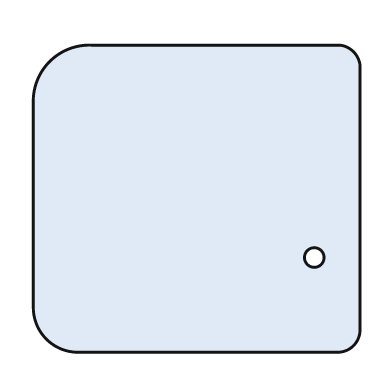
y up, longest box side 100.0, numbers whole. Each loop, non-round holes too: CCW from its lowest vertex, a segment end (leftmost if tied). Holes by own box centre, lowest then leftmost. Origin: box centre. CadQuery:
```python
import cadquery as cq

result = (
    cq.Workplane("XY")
    .moveTo(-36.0, -47.0)
    .lineTo(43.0, -47.0)
    .threePointArc((48.0, -45.0), (50.0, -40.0))
    .lineTo(50.0, 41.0)
    .threePointArc((48.0, 45.0), (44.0, 47.0))
    .lineTo(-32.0, 47.0)
    .threePointArc((-45.0, 42.0), (-50.0, 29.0))
    .lineTo(-50.0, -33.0)
    .threePointArc((-46.0, -43.0), (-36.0, -47.0))
    .close()
    .moveTo(36.0, -18.0)
    .circle(3.0)
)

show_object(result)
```